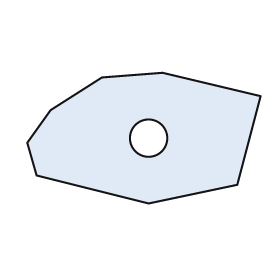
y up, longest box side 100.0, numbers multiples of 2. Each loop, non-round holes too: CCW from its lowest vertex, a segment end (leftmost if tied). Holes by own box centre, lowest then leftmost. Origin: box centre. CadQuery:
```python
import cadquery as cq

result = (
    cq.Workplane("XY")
    .moveTo(2.0, -28.0)
    .lineTo(40.0, -20.0)
    .lineTo(50.0, 18.0)
    .lineTo(8.0, 28.0)
    .lineTo(-18.0, 26.0)
    .lineTo(-40.0, 12.0)
    .lineTo(-50.0, -2.0)
    .lineTo(-46.0, -16.0)
    .close()
    .moveTo(2.0, 0.0)
    .circle(8.0)
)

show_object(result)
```